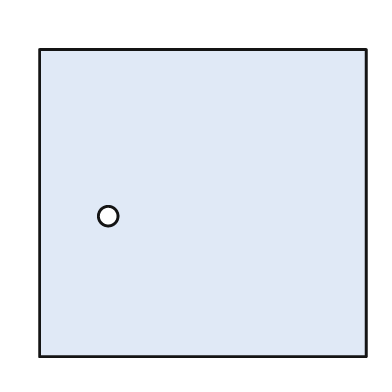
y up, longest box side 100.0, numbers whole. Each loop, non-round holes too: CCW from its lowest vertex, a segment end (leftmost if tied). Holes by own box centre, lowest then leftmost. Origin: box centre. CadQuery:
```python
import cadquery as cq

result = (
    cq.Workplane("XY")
    .moveTo(-50.0, -47.0)
    .lineTo(50.0, -47.0)
    .lineTo(50.0, 47.0)
    .lineTo(-50.0, 47.0)
    .close()
    .moveTo(-29.0, -4.0)
    .circle(3.0)
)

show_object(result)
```